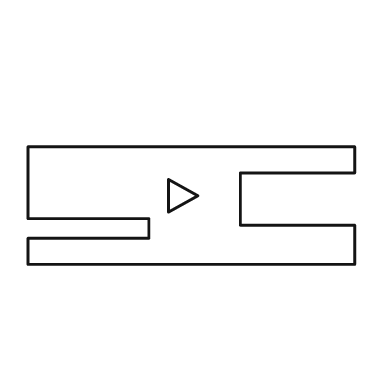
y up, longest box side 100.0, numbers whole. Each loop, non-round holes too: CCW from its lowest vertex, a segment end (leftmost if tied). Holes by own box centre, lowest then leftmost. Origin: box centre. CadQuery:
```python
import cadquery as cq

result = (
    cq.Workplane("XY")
    .moveTo(-50.0, -18.0)
    .lineTo(50.0, -18.0)
    .lineTo(50.0, -6.0)
    .lineTo(15.0, -6.0)
    .lineTo(15.0, 10.0)
    .lineTo(50.0, 10.0)
    .lineTo(50.0, 18.0)
    .lineTo(-50.0, 18.0)
    .lineTo(-50.0, -4.0)
    .lineTo(-13.0, -4.0)
    .lineTo(-13.0, -10.0)
    .lineTo(-50.0, -10.0)
    .close()
    .moveTo(-7.0, -2.0)
    .lineTo(2.0, 3.0)
    .lineTo(-7.0, 8.0)
    .close()
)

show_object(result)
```